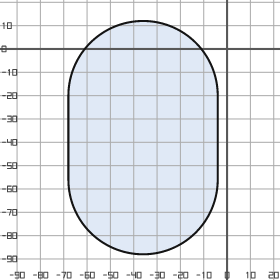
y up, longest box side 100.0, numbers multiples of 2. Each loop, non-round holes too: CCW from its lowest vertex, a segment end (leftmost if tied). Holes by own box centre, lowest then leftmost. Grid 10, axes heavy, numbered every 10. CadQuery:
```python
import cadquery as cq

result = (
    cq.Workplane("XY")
    .moveTo(-68.0, -56.0)
    .threePointArc((-36.0, -88.0), (-4.0, -56.0))
    .lineTo(-4.0, -20.0)
    .threePointArc((-36.0, 12.0), (-68.0, -20.0))
    .close()
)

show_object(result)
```